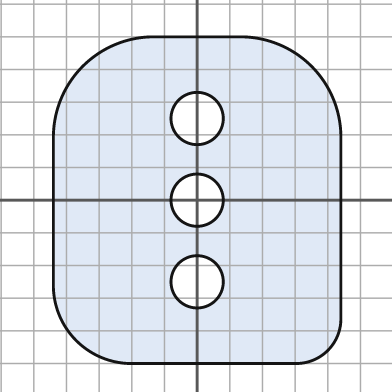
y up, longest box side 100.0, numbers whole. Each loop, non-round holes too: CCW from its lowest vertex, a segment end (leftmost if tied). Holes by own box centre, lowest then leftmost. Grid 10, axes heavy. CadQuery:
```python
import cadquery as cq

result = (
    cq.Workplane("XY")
    .moveTo(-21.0, -50.0)
    .lineTo(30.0, -50.0)
    .threePointArc((40.0, -46.0), (44.0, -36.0))
    .lineTo(44.0, 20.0)
    .threePointArc((35.0, 41.0), (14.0, 50.0))
    .lineTo(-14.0, 50.0)
    .threePointArc((-35.0, 41.0), (-44.0, 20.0))
    .lineTo(-44.0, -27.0)
    .threePointArc((-37.0, -43.0), (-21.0, -50.0))
    .close()
    .moveTo(0.0, -25.0)
    .circle(8.0)
    .moveTo(0.0, 0.0)
    .circle(8.0)
    .moveTo(0.0, 25.0)
    .circle(8.0)
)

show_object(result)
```